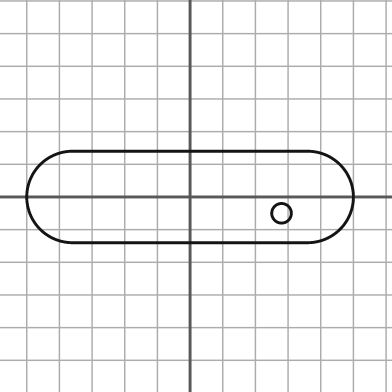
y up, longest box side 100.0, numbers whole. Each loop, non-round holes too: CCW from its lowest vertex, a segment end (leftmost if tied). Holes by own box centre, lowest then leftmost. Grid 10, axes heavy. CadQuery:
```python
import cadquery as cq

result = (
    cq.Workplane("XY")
    .moveTo(-36.0, -14.0)
    .lineTo(36.0, -14.0)
    .threePointArc((50.0, 0.0), (36.0, 14.0))
    .lineTo(-36.0, 14.0)
    .threePointArc((-50.0, 0.0), (-36.0, -14.0))
    .close()
    .moveTo(28.0, -5.0)
    .circle(3.0)
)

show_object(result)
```